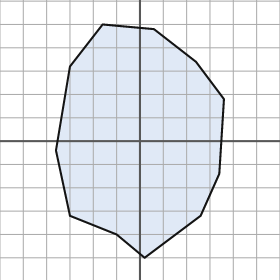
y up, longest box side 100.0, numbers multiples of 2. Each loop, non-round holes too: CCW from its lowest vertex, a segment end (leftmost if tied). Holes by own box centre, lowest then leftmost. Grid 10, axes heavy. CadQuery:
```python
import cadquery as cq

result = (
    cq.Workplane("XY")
    .moveTo(2.0, -50.0)
    .lineTo(26.0, -32.0)
    .lineTo(34.0, -14.0)
    .lineTo(36.0, 18.0)
    .lineTo(24.0, 34.0)
    .lineTo(6.0, 48.0)
    .lineTo(-16.0, 50.0)
    .lineTo(-30.0, 32.0)
    .lineTo(-36.0, -4.0)
    .lineTo(-30.0, -32.0)
    .lineTo(-10.0, -40.0)
    .close()
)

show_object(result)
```